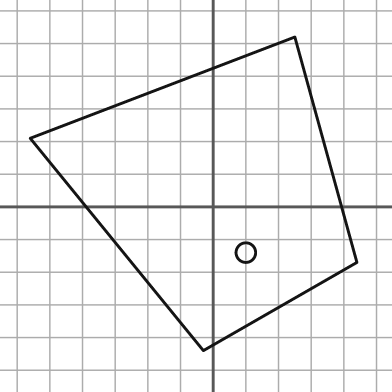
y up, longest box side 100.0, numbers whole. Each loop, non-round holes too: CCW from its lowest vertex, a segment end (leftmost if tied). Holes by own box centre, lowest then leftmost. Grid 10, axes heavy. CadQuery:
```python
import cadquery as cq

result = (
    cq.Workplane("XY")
    .moveTo(-3.0, -44.0)
    .lineTo(44.0, -17.0)
    .lineTo(25.0, 52.0)
    .lineTo(-56.0, 21.0)
    .close()
    .moveTo(10.0, -14.0)
    .circle(3.0)
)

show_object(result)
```